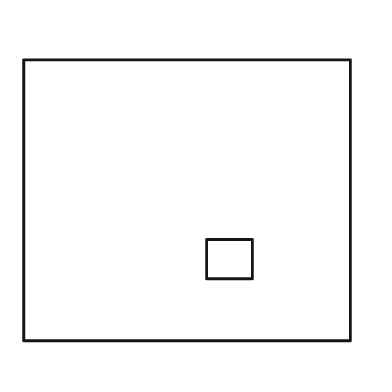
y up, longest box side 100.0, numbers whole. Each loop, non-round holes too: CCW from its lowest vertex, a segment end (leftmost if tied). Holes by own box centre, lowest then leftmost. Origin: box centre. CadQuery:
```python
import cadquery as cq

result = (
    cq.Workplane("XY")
    .moveTo(-50.0, -43.0)
    .lineTo(50.0, -43.0)
    .lineTo(50.0, 43.0)
    .lineTo(-50.0, 43.0)
    .close()
    .moveTo(6.0, -24.0)
    .lineTo(20.0, -24.0)
    .lineTo(20.0, -12.0)
    .lineTo(6.0, -12.0)
    .close()
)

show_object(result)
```